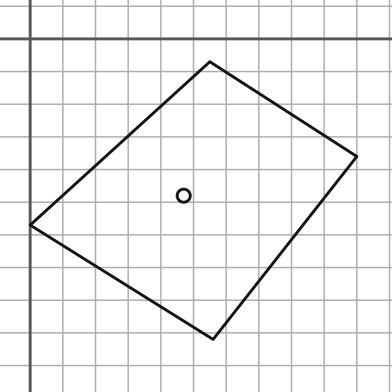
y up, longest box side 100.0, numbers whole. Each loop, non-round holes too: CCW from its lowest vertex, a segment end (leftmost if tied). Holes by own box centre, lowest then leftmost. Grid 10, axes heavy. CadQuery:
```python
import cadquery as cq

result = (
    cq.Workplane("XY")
    .moveTo(56.0, -92.0)
    .lineTo(100.0, -36.0)
    .lineTo(55.0, -7.0)
    .lineTo(0.0, -57.0)
    .close()
    .moveTo(47.0, -48.0)
    .circle(2.0)
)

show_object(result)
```